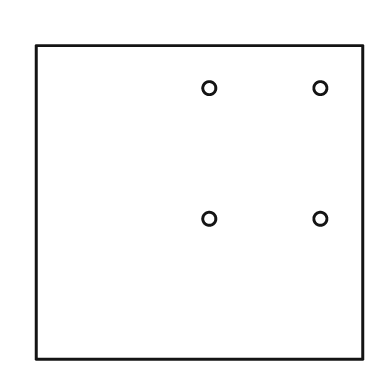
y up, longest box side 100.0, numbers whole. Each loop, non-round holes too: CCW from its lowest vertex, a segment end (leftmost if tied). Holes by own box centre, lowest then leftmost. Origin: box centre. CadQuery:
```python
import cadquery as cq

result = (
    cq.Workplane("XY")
    .moveTo(-50.0, -48.0)
    .lineTo(50.0, -48.0)
    .lineTo(50.0, 48.0)
    .lineTo(-50.0, 48.0)
    .close()
    .moveTo(3.0, -5.0)
    .circle(2.0)
    .moveTo(37.0, -5.0)
    .circle(2.0)
    .moveTo(3.0, 35.0)
    .circle(2.0)
    .moveTo(37.0, 35.0)
    .circle(2.0)
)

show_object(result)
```